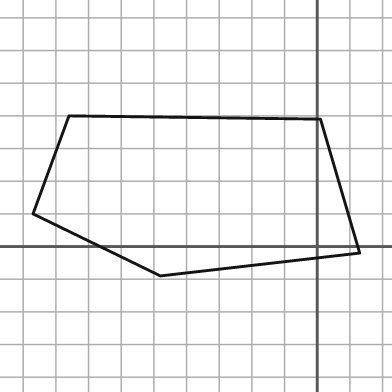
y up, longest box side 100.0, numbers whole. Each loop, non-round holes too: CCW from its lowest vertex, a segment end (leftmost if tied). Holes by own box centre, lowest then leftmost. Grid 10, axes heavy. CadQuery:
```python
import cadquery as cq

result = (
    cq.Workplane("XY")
    .moveTo(-48.0, -9.0)
    .lineTo(13.0, -2.0)
    .lineTo(1.0, 39.0)
    .lineTo(-76.0, 40.0)
    .lineTo(-87.0, 10.0)
    .close()
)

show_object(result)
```